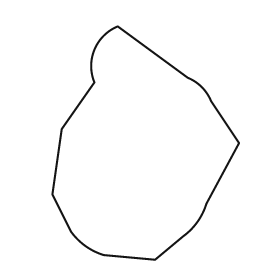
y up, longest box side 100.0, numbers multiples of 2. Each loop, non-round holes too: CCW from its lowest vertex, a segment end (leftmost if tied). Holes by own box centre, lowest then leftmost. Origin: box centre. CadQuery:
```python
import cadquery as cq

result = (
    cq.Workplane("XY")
    .moveTo(4.0, -50.0)
    .lineTo(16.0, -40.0)
    .threePointArc((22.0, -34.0), (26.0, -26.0))
    .lineTo(40.0, 0.0)
    .lineTo(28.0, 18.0)
    .threePointArc((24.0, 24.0), (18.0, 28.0))
    .lineTo(-12.0, 50.0)
    .threePointArc((-22.0, 40.0), (-22.0, 26.0))
    .lineTo(-36.0, 6.0)
    .lineTo(-40.0, -22.0)
    .lineTo(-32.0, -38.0)
    .threePointArc((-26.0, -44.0), (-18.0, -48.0))
    .close()
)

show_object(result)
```